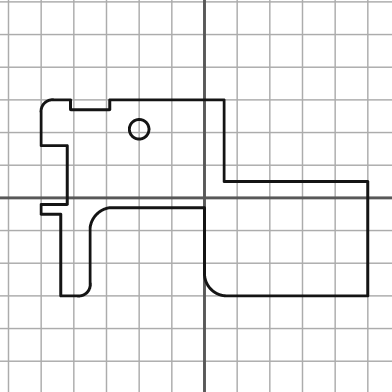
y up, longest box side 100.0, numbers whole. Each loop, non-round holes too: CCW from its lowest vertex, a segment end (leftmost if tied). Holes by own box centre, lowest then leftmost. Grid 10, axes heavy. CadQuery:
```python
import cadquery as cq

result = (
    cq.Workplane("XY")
    .moveTo(-44.0, -30.0)
    .lineTo(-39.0, -30.0)
    .threePointArc((-36.0, -29.0), (-35.0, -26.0))
    .lineTo(-35.0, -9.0)
    .threePointArc((-33.0, -5.0), (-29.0, -3.0))
    .lineTo(0.0, -3.0)
    .lineTo(0.0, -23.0)
    .threePointArc((2.0, -28.0), (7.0, -30.0))
    .lineTo(50.0, -30.0)
    .lineTo(50.0, 5.0)
    .lineTo(6.0, 5.0)
    .lineTo(6.0, 30.0)
    .lineTo(-29.0, 30.0)
    .lineTo(-29.0, 27.0)
    .lineTo(-41.0, 27.0)
    .lineTo(-41.0, 30.0)
    .lineTo(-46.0, 30.0)
    .threePointArc((-49.0, 29.0), (-50.0, 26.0))
    .lineTo(-50.0, 16.0)
    .lineTo(-42.0, 16.0)
    .lineTo(-42.0, -2.0)
    .lineTo(-50.0, -2.0)
    .lineTo(-50.0, -5.0)
    .lineTo(-44.0, -5.0)
    .close()
    .moveTo(-20.0, 21.0)
    .circle(3.0)
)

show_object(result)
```